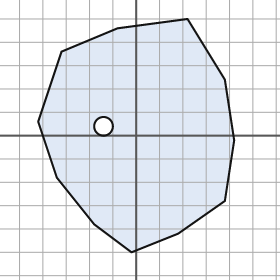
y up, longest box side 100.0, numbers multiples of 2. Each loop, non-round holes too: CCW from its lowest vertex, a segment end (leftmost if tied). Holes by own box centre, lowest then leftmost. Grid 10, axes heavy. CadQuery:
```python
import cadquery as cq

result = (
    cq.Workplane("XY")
    .moveTo(-2.0, -50.0)
    .lineTo(18.0, -42.0)
    .lineTo(38.0, -28.0)
    .lineTo(42.0, -2.0)
    .lineTo(38.0, 24.0)
    .lineTo(22.0, 50.0)
    .lineTo(-8.0, 46.0)
    .lineTo(-32.0, 36.0)
    .lineTo(-42.0, 6.0)
    .lineTo(-34.0, -18.0)
    .lineTo(-18.0, -38.0)
    .close()
    .moveTo(-14.0, 4.0)
    .circle(4.0)
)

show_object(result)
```